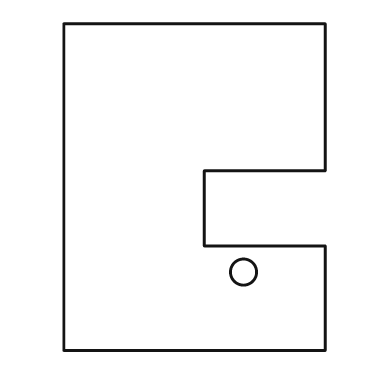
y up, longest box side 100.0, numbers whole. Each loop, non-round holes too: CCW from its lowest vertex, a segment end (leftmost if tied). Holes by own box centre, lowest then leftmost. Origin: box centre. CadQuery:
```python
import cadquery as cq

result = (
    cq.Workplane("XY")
    .moveTo(-40.0, -50.0)
    .lineTo(40.0, -50.0)
    .lineTo(40.0, -18.0)
    .lineTo(3.0, -18.0)
    .lineTo(3.0, 5.0)
    .lineTo(40.0, 5.0)
    .lineTo(40.0, 50.0)
    .lineTo(-40.0, 50.0)
    .close()
    .moveTo(15.0, -26.0)
    .circle(4.0)
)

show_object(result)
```